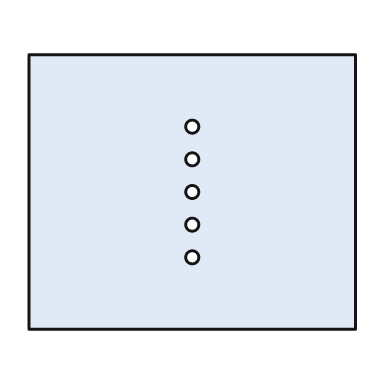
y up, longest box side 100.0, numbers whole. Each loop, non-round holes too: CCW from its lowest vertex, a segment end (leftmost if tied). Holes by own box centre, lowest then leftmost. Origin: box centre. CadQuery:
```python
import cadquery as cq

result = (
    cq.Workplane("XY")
    .moveTo(-50.0, -42.0)
    .lineTo(50.0, -42.0)
    .lineTo(50.0, 42.0)
    .lineTo(-50.0, 42.0)
    .close()
    .moveTo(0.0, -20.0)
    .circle(2.0)
    .moveTo(0.0, -10.0)
    .circle(2.0)
    .moveTo(0.0, 0.0)
    .circle(2.0)
    .moveTo(0.0, 10.0)
    .circle(2.0)
    .moveTo(0.0, 20.0)
    .circle(2.0)
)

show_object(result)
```